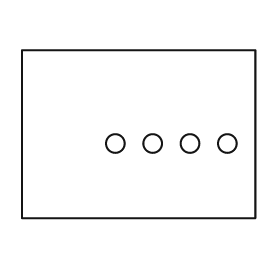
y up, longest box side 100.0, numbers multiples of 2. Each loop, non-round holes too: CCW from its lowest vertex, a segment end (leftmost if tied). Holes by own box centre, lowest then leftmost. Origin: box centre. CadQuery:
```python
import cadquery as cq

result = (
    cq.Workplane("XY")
    .moveTo(-50.0, -36.0)
    .lineTo(50.0, -36.0)
    .lineTo(50.0, 36.0)
    .lineTo(-50.0, 36.0)
    .close()
    .moveTo(-10.0, -4.0)
    .circle(4.0)
    .moveTo(6.0, -4.0)
    .circle(4.0)
    .moveTo(22.0, -4.0)
    .circle(4.0)
    .moveTo(38.0, -4.0)
    .circle(4.0)
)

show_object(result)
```